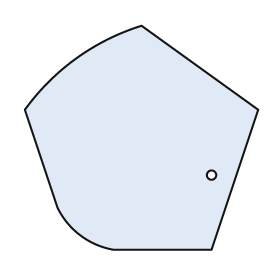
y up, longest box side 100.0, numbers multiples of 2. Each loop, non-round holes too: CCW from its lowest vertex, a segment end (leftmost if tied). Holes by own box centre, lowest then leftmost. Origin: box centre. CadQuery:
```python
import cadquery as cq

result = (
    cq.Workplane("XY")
    .moveTo(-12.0, -48.0)
    .lineTo(30.0, -48.0)
    .lineTo(50.0, 12.0)
    .lineTo(0.0, 48.0)
    .threePointArc((-28.0, 34.0), (-50.0, 12.0))
    .lineTo(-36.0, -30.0)
    .threePointArc((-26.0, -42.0), (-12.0, -48.0))
    .close()
    .moveTo(30.0, -16.0)
    .circle(2.0)
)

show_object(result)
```